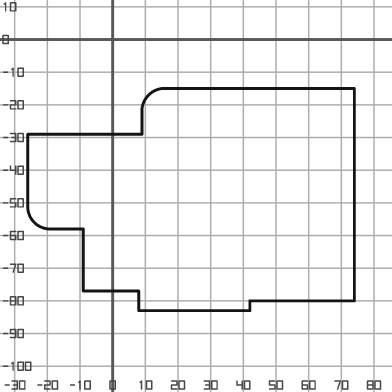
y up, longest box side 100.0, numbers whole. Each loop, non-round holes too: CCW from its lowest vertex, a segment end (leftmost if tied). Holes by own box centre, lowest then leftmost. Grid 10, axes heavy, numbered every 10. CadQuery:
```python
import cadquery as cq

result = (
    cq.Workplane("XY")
    .moveTo(8.0, -83.0)
    .lineTo(42.0, -83.0)
    .lineTo(42.0, -80.0)
    .lineTo(74.0, -80.0)
    .lineTo(74.0, -15.0)
    .lineTo(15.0, -15.0)
    .threePointArc((11.0, -17.0), (9.0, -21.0))
    .lineTo(9.0, -29.0)
    .lineTo(-26.0, -29.0)
    .lineTo(-26.0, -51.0)
    .threePointArc((-24.0, -56.0), (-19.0, -58.0))
    .lineTo(-9.0, -58.0)
    .lineTo(-9.0, -77.0)
    .lineTo(8.0, -77.0)
    .close()
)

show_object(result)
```